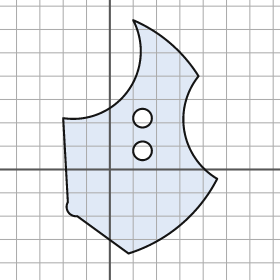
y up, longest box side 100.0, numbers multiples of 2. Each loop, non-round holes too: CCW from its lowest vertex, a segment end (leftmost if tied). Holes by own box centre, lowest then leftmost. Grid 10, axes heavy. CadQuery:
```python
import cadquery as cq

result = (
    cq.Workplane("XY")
    .moveTo(8.0, -36.0)
    .threePointArc((30.0, -24.0), (46.0, -4.0))
    .threePointArc((32.0, 16.0), (38.0, 40.0))
    .threePointArc((26.0, 54.0), (10.0, 64.0))
    .threePointArc((8.0, 34.0), (-20.0, 22.0))
    .lineTo(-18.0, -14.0)
    .threePointArc((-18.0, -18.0), (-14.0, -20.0))
    .close()
    .moveTo(14.0, 8.0)
    .circle(4.0)
    .moveTo(14.0, 22.0)
    .circle(4.0)
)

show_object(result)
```